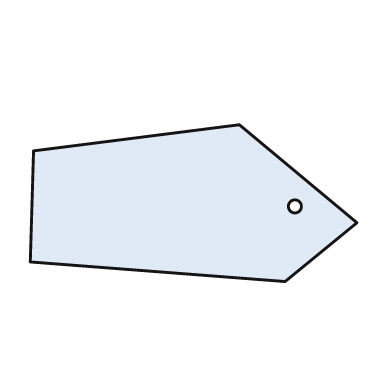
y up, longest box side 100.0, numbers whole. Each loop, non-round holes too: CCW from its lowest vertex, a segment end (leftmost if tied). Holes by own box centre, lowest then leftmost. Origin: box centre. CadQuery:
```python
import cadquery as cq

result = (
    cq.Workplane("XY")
    .moveTo(28.0, -24.0)
    .lineTo(50.0, -6.0)
    .lineTo(14.0, 24.0)
    .lineTo(-49.0, 16.0)
    .lineTo(-50.0, -18.0)
    .close()
    .moveTo(31.0, -1.0)
    .circle(2.0)
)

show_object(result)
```